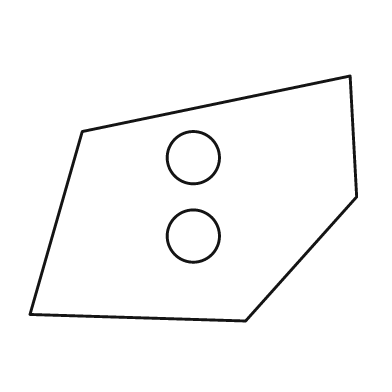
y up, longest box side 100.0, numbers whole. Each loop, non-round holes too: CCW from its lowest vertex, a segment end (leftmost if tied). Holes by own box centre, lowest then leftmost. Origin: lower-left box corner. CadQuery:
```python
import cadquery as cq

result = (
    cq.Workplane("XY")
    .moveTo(66.0, 0.0)
    .lineTo(100.0, 38.0)
    .lineTo(98.0, 75.0)
    .lineTo(16.0, 58.0)
    .lineTo(0.0, 2.0)
    .close()
    .moveTo(50.0, 26.0)
    .circle(8.0)
    .moveTo(50.0, 50.0)
    .circle(8.0)
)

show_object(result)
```